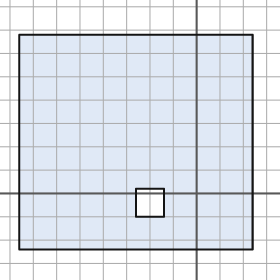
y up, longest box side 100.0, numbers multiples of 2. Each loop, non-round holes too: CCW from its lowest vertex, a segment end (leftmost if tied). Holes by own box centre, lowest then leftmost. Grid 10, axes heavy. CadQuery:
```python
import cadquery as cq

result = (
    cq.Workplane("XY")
    .moveTo(-76.0, -24.0)
    .lineTo(24.0, -24.0)
    .lineTo(24.0, 68.0)
    .lineTo(-76.0, 68.0)
    .close()
    .moveTo(-26.0, -10.0)
    .lineTo(-14.0, -10.0)
    .lineTo(-14.0, 2.0)
    .lineTo(-26.0, 2.0)
    .close()
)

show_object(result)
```